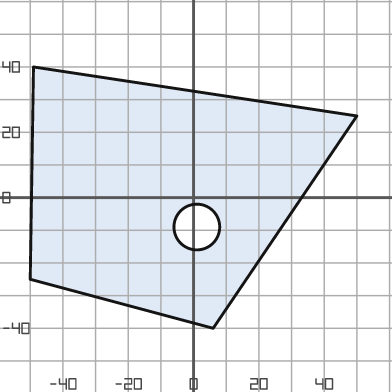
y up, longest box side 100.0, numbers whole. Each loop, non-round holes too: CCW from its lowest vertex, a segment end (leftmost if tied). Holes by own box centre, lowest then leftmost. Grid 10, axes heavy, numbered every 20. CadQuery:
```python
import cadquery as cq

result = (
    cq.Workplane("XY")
    .moveTo(6.0, -40.0)
    .lineTo(50.0, 25.0)
    .lineTo(-49.0, 40.0)
    .lineTo(-50.0, -25.0)
    .close()
    .moveTo(1.0, -9.0)
    .circle(7.0)
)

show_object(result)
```